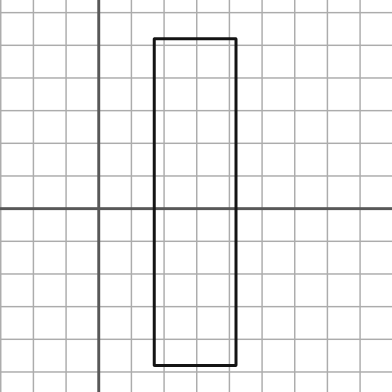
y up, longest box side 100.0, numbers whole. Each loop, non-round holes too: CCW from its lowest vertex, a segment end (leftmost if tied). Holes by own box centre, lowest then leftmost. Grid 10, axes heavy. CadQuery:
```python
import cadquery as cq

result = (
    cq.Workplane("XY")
    .moveTo(17.0, -48.0)
    .lineTo(42.0, -48.0)
    .lineTo(42.0, 52.0)
    .lineTo(17.0, 52.0)
    .close()
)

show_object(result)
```